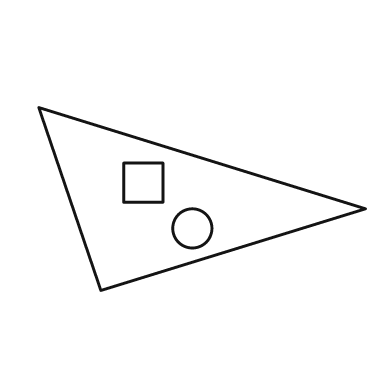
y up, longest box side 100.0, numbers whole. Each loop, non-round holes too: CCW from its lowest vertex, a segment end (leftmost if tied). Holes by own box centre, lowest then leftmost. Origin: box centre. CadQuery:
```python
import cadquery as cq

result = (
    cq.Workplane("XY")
    .moveTo(-31.0, -28.0)
    .lineTo(50.0, -3.0)
    .lineTo(-50.0, 28.0)
    .close()
    .moveTo(-3.0, -9.0)
    .circle(6.0)
    .moveTo(-24.0, -1.0)
    .lineTo(-12.0, -1.0)
    .lineTo(-12.0, 11.0)
    .lineTo(-24.0, 11.0)
    .close()
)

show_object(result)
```